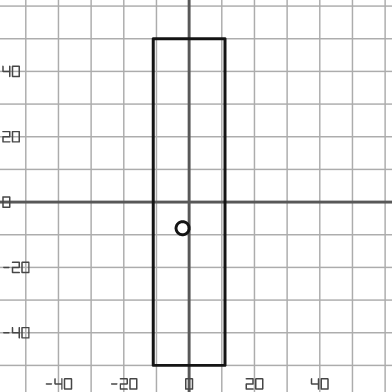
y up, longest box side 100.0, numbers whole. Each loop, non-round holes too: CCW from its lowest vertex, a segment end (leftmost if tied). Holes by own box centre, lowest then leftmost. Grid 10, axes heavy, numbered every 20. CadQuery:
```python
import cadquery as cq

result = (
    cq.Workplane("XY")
    .moveTo(-11.0, -50.0)
    .lineTo(11.0, -50.0)
    .lineTo(11.0, 50.0)
    .lineTo(-11.0, 50.0)
    .close()
    .moveTo(-2.0, -8.0)
    .circle(2.0)
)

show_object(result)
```